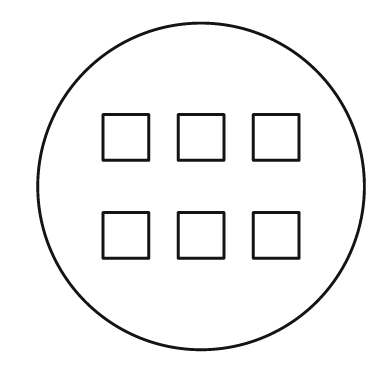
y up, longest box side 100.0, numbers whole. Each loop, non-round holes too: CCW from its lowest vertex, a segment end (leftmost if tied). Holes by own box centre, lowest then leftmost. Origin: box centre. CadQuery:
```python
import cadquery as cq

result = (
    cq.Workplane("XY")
    .moveTo(0.0, 0.0)
    .circle(50.0)
    .moveTo(-30.0, -22.0)
    .lineTo(-16.0, -22.0)
    .lineTo(-16.0, -8.0)
    .lineTo(-30.0, -8.0)
    .close()
    .moveTo(-7.0, -22.0)
    .lineTo(7.0, -22.0)
    .lineTo(7.0, -8.0)
    .lineTo(-7.0, -8.0)
    .close()
    .moveTo(16.0, -22.0)
    .lineTo(30.0, -22.0)
    .lineTo(30.0, -8.0)
    .lineTo(16.0, -8.0)
    .close()
    .moveTo(-30.0, 8.0)
    .lineTo(-16.0, 8.0)
    .lineTo(-16.0, 22.0)
    .lineTo(-30.0, 22.0)
    .close()
    .moveTo(-7.0, 8.0)
    .lineTo(7.0, 8.0)
    .lineTo(7.0, 22.0)
    .lineTo(-7.0, 22.0)
    .close()
    .moveTo(16.0, 8.0)
    .lineTo(30.0, 8.0)
    .lineTo(30.0, 22.0)
    .lineTo(16.0, 22.0)
    .close()
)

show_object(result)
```